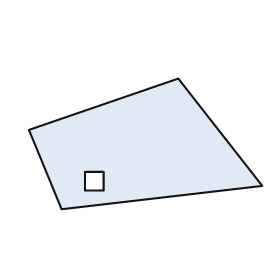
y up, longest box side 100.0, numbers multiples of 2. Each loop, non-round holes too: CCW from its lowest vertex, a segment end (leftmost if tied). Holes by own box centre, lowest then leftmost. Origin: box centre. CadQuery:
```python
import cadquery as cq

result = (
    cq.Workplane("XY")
    .moveTo(-36.0, -28.0)
    .lineTo(50.0, -18.0)
    .lineTo(14.0, 28.0)
    .lineTo(-50.0, 6.0)
    .close()
    .moveTo(-26.0, -20.0)
    .lineTo(-18.0, -20.0)
    .lineTo(-18.0, -12.0)
    .lineTo(-26.0, -12.0)
    .close()
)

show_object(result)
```